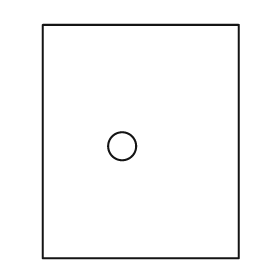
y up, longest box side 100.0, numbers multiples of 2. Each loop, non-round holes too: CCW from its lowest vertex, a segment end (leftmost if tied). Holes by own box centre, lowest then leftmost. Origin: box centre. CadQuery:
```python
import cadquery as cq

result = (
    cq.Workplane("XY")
    .moveTo(-42.0, -50.0)
    .lineTo(42.0, -50.0)
    .lineTo(42.0, 50.0)
    .lineTo(-42.0, 50.0)
    .close()
    .moveTo(-8.0, -2.0)
    .circle(6.0)
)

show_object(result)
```